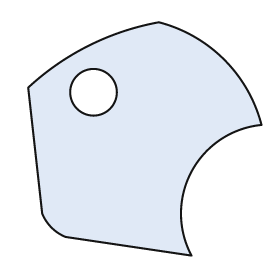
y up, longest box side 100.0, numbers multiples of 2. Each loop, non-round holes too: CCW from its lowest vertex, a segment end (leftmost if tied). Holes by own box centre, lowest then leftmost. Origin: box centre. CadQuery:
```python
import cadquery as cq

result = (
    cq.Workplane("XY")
    .moveTo(20.0, -50.0)
    .threePointArc((20.0, -14.0), (50.0, 6.0))
    .threePointArc((34.0, 34.0), (6.0, 50.0))
    .threePointArc((-24.0, 40.0), (-50.0, 22.0))
    .lineTo(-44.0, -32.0)
    .threePointArc((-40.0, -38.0), (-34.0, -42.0))
    .close()
    .moveTo(-22.0, 20.0)
    .circle(10.0)
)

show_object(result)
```